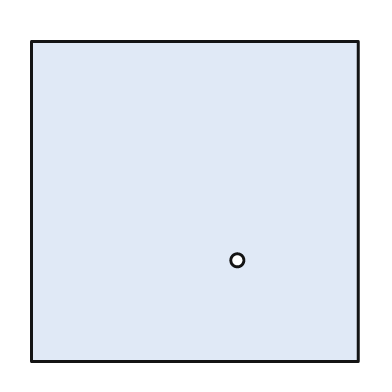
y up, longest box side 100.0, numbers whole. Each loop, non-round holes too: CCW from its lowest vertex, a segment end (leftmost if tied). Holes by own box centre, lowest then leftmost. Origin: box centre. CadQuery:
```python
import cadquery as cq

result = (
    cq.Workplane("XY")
    .moveTo(-50.0, -49.0)
    .lineTo(50.0, -49.0)
    .lineTo(50.0, 49.0)
    .lineTo(-50.0, 49.0)
    .close()
    .moveTo(13.0, -18.0)
    .circle(2.0)
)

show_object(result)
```